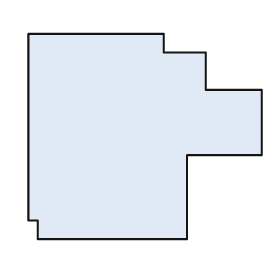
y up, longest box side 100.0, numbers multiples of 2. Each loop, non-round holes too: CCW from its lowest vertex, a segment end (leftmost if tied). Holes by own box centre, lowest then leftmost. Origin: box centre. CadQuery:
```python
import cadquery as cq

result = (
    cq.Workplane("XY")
    .moveTo(-46.0, -44.0)
    .lineTo(18.0, -44.0)
    .lineTo(18.0, -8.0)
    .lineTo(50.0, -8.0)
    .lineTo(50.0, 20.0)
    .lineTo(26.0, 20.0)
    .lineTo(26.0, 36.0)
    .lineTo(8.0, 36.0)
    .lineTo(8.0, 44.0)
    .lineTo(-50.0, 44.0)
    .lineTo(-50.0, -36.0)
    .lineTo(-46.0, -36.0)
    .close()
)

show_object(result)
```